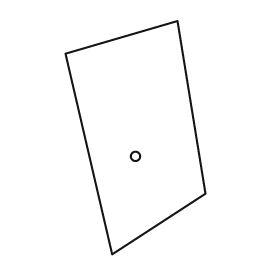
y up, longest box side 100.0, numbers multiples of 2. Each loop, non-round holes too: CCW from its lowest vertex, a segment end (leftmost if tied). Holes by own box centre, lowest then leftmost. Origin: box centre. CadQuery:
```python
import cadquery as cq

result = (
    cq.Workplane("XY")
    .moveTo(-10.0, -50.0)
    .lineTo(30.0, -24.0)
    .lineTo(18.0, 50.0)
    .lineTo(-30.0, 36.0)
    .close()
    .moveTo(0.0, -8.0)
    .circle(2.0)
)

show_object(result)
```